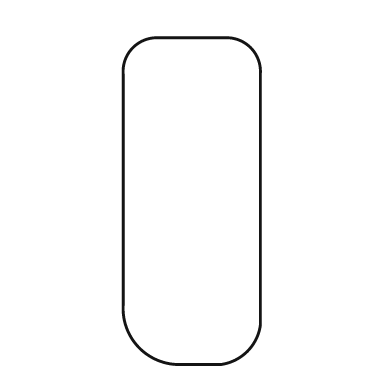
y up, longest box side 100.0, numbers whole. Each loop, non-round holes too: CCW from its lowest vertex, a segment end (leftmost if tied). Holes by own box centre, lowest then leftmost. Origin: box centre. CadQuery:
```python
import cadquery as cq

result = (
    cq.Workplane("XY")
    .moveTo(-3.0, -50.0)
    .lineTo(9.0, -50.0)
    .threePointArc((17.0, -46.0), (21.0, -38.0))
    .lineTo(21.0, 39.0)
    .threePointArc((18.0, 47.0), (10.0, 50.0))
    .lineTo(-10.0, 50.0)
    .threePointArc((-18.0, 47.0), (-21.0, 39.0))
    .lineTo(-21.0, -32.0)
    .threePointArc((-16.0, -45.0), (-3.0, -50.0))
    .close()
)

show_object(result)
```